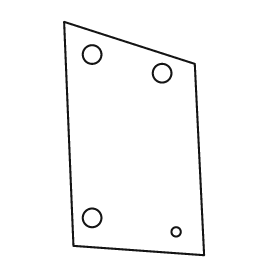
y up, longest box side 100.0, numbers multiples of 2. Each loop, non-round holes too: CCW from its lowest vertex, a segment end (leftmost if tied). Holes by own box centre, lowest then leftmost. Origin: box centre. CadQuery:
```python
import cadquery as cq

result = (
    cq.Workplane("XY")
    .moveTo(30.0, -50.0)
    .lineTo(26.0, 32.0)
    .lineTo(-30.0, 50.0)
    .lineTo(-26.0, -46.0)
    .close()
    .moveTo(18.0, -40.0)
    .circle(2.0)
    .moveTo(-18.0, -34.0)
    .circle(4.0)
    .moveTo(12.0, 28.0)
    .circle(4.0)
    .moveTo(-18.0, 36.0)
    .circle(4.0)
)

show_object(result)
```